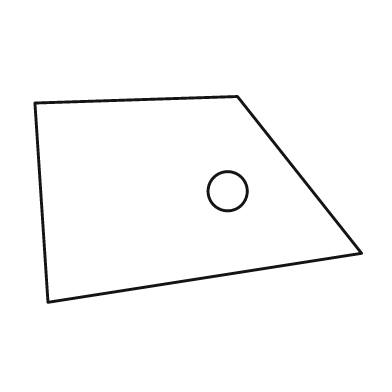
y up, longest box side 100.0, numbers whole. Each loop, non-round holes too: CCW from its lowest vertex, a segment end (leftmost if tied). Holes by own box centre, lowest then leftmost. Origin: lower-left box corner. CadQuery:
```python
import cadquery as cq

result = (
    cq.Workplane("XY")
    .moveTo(4.0, 0.0)
    .lineTo(100.0, 15.0)
    .lineTo(62.0, 63.0)
    .lineTo(0.0, 61.0)
    .close()
    .moveTo(59.0, 34.0)
    .circle(6.0)
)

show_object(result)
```